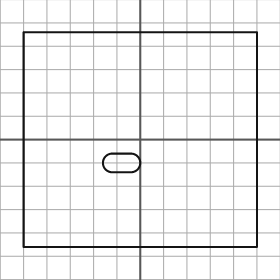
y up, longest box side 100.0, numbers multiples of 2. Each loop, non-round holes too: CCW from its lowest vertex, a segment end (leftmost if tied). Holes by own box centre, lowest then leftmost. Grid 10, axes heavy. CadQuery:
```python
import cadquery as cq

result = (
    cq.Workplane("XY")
    .moveTo(-50.0, -46.0)
    .lineTo(50.0, -46.0)
    .lineTo(50.0, 46.0)
    .lineTo(-50.0, 46.0)
    .close()
    .moveTo(-12.0, -14.0)
    .lineTo(-4.0, -14.0)
    .threePointArc((0.0, -10.0), (-4.0, -6.0))
    .lineTo(-12.0, -6.0)
    .threePointArc((-16.0, -10.0), (-12.0, -14.0))
    .close()
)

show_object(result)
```